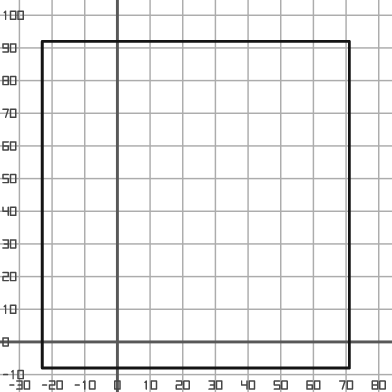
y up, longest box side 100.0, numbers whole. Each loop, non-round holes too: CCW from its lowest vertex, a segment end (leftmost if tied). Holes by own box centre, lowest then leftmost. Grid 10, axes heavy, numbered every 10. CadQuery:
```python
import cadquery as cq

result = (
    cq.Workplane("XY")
    .moveTo(-23.0, -8.0)
    .lineTo(71.0, -8.0)
    .lineTo(71.0, 92.0)
    .lineTo(-23.0, 92.0)
    .close()
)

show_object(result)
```